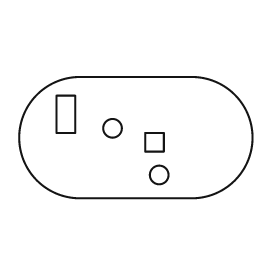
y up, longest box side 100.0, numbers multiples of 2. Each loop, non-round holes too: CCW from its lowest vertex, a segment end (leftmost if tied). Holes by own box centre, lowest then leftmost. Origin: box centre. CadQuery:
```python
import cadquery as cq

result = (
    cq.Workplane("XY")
    .moveTo(-24.0, -26.0)
    .lineTo(24.0, -26.0)
    .threePointArc((50.0, 0.0), (24.0, 26.0))
    .lineTo(-24.0, 26.0)
    .threePointArc((-50.0, 0.0), (-24.0, -26.0))
    .close()
    .moveTo(10.0, -16.0)
    .circle(4.0)
    .moveTo(4.0, -6.0)
    .lineTo(12.0, -6.0)
    .lineTo(12.0, 2.0)
    .lineTo(4.0, 2.0)
    .close()
    .moveTo(-10.0, 4.0)
    .circle(4.0)
    .moveTo(-34.0, 2.0)
    .lineTo(-26.0, 2.0)
    .lineTo(-26.0, 18.0)
    .lineTo(-34.0, 18.0)
    .close()
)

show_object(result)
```